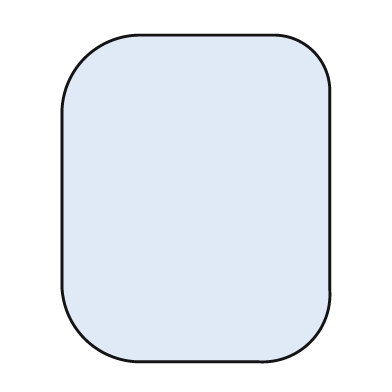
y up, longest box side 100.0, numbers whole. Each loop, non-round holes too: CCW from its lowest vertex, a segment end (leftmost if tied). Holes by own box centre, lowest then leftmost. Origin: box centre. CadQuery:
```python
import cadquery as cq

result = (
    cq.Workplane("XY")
    .moveTo(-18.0, -50.0)
    .lineTo(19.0, -50.0)
    .threePointArc((35.0, -44.0), (41.0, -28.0))
    .lineTo(41.0, 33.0)
    .threePointArc((36.0, 45.0), (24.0, 50.0))
    .lineTo(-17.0, 50.0)
    .threePointArc((-34.0, 43.0), (-41.0, 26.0))
    .lineTo(-41.0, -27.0)
    .threePointArc((-34.0, -43.0), (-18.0, -50.0))
    .close()
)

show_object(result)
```